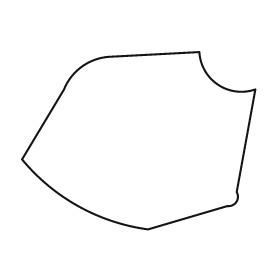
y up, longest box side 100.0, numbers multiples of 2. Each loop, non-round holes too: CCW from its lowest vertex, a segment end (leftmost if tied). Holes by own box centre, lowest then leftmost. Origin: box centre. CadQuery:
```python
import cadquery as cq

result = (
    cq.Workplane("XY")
    .moveTo(4.0, -38.0)
    .lineTo(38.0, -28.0)
    .threePointArc((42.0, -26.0), (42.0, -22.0))
    .lineTo(50.0, 22.0)
    .threePointArc((34.0, 24.0), (26.0, 38.0))
    .lineTo(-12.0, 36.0)
    .threePointArc((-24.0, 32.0), (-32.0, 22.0))
    .lineTo(-50.0, -8.0)
    .threePointArc((-26.0, -28.0), (4.0, -38.0))
    .close()
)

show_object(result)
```